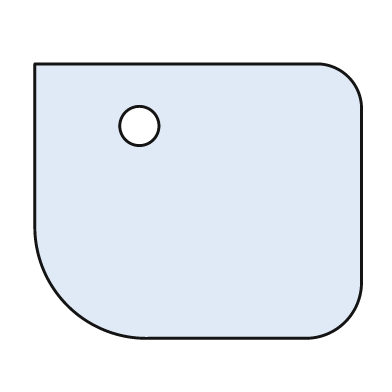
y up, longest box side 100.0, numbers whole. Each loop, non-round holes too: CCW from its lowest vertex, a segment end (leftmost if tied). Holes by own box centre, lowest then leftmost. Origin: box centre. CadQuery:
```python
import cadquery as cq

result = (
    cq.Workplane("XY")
    .moveTo(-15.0, -42.0)
    .lineTo(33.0, -42.0)
    .threePointArc((45.0, -37.0), (50.0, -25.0))
    .lineTo(50.0, 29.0)
    .threePointArc((46.0, 38.0), (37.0, 42.0))
    .lineTo(-50.0, 42.0)
    .lineTo(-50.0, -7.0)
    .threePointArc((-40.0, -32.0), (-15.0, -42.0))
    .close()
    .moveTo(-18.0, 23.0)
    .circle(6.0)
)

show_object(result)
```